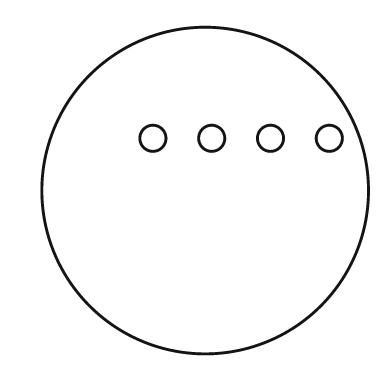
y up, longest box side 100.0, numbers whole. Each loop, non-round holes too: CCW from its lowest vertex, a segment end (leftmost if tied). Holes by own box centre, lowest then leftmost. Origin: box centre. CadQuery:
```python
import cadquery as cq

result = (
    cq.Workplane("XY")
    .moveTo(0.0, 0.0)
    .circle(50.0)
    .moveTo(-16.0, 16.0)
    .circle(4.0)
    .moveTo(2.0, 16.0)
    .circle(4.0)
    .moveTo(20.0, 16.0)
    .circle(4.0)
    .moveTo(38.0, 16.0)
    .circle(4.0)
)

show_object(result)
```